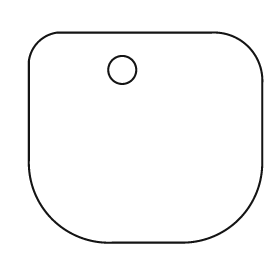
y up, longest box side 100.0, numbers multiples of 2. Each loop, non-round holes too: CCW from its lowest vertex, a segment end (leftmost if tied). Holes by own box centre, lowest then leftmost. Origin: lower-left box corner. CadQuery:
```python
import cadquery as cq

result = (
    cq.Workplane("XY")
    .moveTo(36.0, 0.0)
    .lineTo(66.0, 0.0)
    .threePointArc((90.0, 10.0), (100.0, 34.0))
    .lineTo(100.0, 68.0)
    .threePointArc((94.0, 84.0), (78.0, 90.0))
    .lineTo(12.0, 90.0)
    .threePointArc((4.0, 86.0), (0.0, 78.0))
    .lineTo(0.0, 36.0)
    .threePointArc((10.0, 10.0), (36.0, 0.0))
    .close()
    .moveTo(40.0, 74.0)
    .circle(6.0)
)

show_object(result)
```